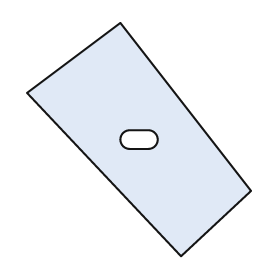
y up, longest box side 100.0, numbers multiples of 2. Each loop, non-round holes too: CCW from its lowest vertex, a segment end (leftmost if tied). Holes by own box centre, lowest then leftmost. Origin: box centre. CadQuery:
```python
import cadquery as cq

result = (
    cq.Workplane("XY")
    .moveTo(18.0, -50.0)
    .lineTo(48.0, -22.0)
    .lineTo(-8.0, 50.0)
    .lineTo(-48.0, 20.0)
    .close()
    .moveTo(-4.0, -4.0)
    .lineTo(4.0, -4.0)
    .threePointArc((8.0, 0.0), (4.0, 4.0))
    .lineTo(-4.0, 4.0)
    .threePointArc((-8.0, 0.0), (-4.0, -4.0))
    .close()
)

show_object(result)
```